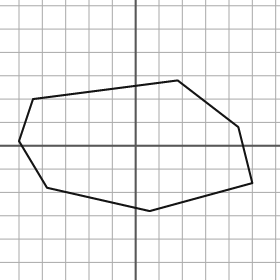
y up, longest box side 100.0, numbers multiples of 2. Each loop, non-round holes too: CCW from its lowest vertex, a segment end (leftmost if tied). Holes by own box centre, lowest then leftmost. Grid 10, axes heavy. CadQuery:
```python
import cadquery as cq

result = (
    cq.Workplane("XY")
    .moveTo(6.0, -28.0)
    .lineTo(50.0, -16.0)
    .lineTo(44.0, 8.0)
    .lineTo(18.0, 28.0)
    .lineTo(-44.0, 20.0)
    .lineTo(-50.0, 2.0)
    .lineTo(-38.0, -18.0)
    .close()
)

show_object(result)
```